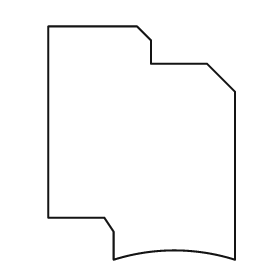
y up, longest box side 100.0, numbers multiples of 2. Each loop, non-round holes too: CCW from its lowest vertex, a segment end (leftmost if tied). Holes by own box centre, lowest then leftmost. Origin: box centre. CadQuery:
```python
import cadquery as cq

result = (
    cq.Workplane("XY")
    .moveTo(-12.0, -50.0)
    .threePointArc((14.0, -46.0), (40.0, -50.0))
    .lineTo(40.0, 22.0)
    .lineTo(28.0, 34.0)
    .lineTo(4.0, 34.0)
    .lineTo(4.0, 44.0)
    .lineTo(-2.0, 50.0)
    .lineTo(-40.0, 50.0)
    .lineTo(-40.0, -32.0)
    .lineTo(-16.0, -32.0)
    .lineTo(-12.0, -38.0)
    .close()
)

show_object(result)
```